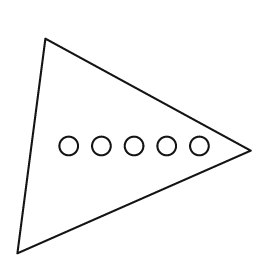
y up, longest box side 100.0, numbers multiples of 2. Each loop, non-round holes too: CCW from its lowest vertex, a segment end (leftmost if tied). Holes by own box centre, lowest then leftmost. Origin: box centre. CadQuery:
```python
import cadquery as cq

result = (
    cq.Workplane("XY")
    .moveTo(-50.0, -46.0)
    .lineTo(50.0, -2.0)
    .lineTo(-38.0, 46.0)
    .close()
    .moveTo(-28.0, 0.0)
    .circle(4.0)
    .moveTo(-14.0, 0.0)
    .circle(4.0)
    .moveTo(0.0, 0.0)
    .circle(4.0)
    .moveTo(14.0, 0.0)
    .circle(4.0)
    .moveTo(28.0, 0.0)
    .circle(4.0)
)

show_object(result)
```